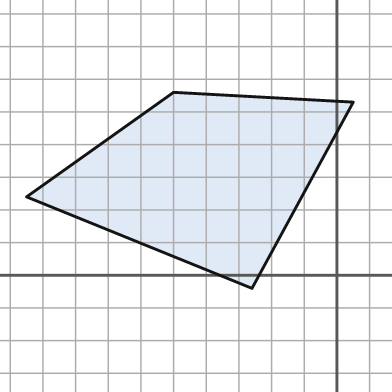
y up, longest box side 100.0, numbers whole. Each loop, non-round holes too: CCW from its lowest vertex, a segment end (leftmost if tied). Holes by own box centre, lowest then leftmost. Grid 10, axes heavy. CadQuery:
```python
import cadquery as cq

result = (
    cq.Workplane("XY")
    .moveTo(-26.0, -4.0)
    .lineTo(5.0, 53.0)
    .lineTo(-50.0, 56.0)
    .lineTo(-95.0, 24.0)
    .close()
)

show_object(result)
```